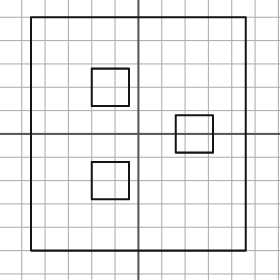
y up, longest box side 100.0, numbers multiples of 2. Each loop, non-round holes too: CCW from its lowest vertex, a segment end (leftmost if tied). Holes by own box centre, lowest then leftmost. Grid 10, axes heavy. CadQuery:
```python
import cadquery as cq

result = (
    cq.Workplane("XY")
    .moveTo(-46.0, -50.0)
    .lineTo(46.0, -50.0)
    .lineTo(46.0, 50.0)
    .lineTo(-46.0, 50.0)
    .close()
    .moveTo(-20.0, -28.0)
    .lineTo(-4.0, -28.0)
    .lineTo(-4.0, -12.0)
    .lineTo(-20.0, -12.0)
    .close()
    .moveTo(16.0, -8.0)
    .lineTo(32.0, -8.0)
    .lineTo(32.0, 8.0)
    .lineTo(16.0, 8.0)
    .close()
    .moveTo(-20.0, 12.0)
    .lineTo(-4.0, 12.0)
    .lineTo(-4.0, 28.0)
    .lineTo(-20.0, 28.0)
    .close()
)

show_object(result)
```